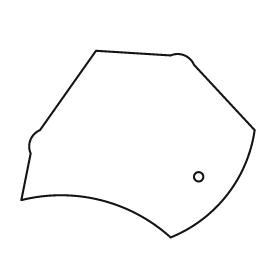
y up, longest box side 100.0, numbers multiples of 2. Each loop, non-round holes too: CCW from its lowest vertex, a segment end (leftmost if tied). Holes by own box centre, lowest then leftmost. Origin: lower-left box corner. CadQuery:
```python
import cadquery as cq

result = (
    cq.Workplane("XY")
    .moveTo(64.0, 0.0)
    .threePointArc((88.0, 18.0), (100.0, 46.0))
    .lineTo(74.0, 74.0)
    .threePointArc((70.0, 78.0), (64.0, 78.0))
    .lineTo(32.0, 80.0)
    .lineTo(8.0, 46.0)
    .threePointArc((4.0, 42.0), (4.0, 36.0))
    .lineTo(0.0, 16.0)
    .threePointArc((34.0, 16.0), (64.0, 0.0))
    .close()
    .moveTo(76.0, 26.0)
    .circle(2.0)
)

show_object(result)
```